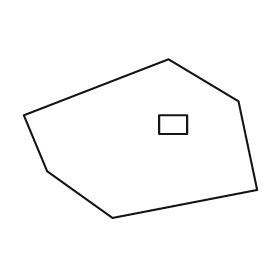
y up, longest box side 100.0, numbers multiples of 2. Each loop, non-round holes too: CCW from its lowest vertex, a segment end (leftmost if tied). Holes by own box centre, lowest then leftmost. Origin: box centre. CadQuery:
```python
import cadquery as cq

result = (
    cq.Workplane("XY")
    .moveTo(-12.0, -34.0)
    .lineTo(50.0, -22.0)
    .lineTo(42.0, 16.0)
    .lineTo(12.0, 34.0)
    .lineTo(-50.0, 10.0)
    .lineTo(-40.0, -14.0)
    .close()
    .moveTo(8.0, 2.0)
    .lineTo(20.0, 2.0)
    .lineTo(20.0, 10.0)
    .lineTo(8.0, 10.0)
    .close()
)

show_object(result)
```